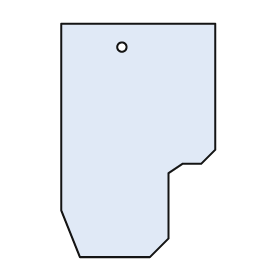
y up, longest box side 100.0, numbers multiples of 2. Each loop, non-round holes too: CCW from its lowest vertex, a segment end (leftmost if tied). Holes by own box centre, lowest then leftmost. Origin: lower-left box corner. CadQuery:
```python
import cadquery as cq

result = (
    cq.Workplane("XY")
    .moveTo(8.0, 0.0)
    .lineTo(38.0, 0.0)
    .lineTo(46.0, 8.0)
    .lineTo(46.0, 36.0)
    .lineTo(52.0, 40.0)
    .lineTo(60.0, 40.0)
    .lineTo(66.0, 46.0)
    .lineTo(66.0, 100.0)
    .lineTo(0.0, 100.0)
    .lineTo(0.0, 20.0)
    .close()
    .moveTo(26.0, 90.0)
    .circle(2.0)
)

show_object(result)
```